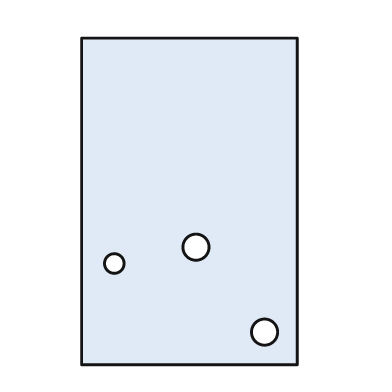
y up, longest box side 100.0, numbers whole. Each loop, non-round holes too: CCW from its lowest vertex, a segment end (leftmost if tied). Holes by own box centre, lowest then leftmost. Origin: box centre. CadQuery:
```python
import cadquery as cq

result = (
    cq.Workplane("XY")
    .moveTo(-33.0, -50.0)
    .lineTo(33.0, -50.0)
    .lineTo(33.0, 50.0)
    .lineTo(-33.0, 50.0)
    .close()
    .moveTo(23.0, -40.0)
    .circle(4.0)
    .moveTo(-23.0, -19.0)
    .circle(3.0)
    .moveTo(2.0, -14.0)
    .circle(4.0)
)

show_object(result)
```